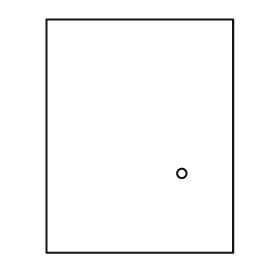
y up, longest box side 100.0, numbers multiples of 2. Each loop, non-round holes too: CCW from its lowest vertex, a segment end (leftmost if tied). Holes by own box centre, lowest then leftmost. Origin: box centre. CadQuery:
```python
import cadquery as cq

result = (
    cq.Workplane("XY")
    .moveTo(-40.0, -50.0)
    .lineTo(40.0, -50.0)
    .lineTo(40.0, 50.0)
    .lineTo(-40.0, 50.0)
    .close()
    .moveTo(18.0, -16.0)
    .circle(2.0)
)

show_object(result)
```